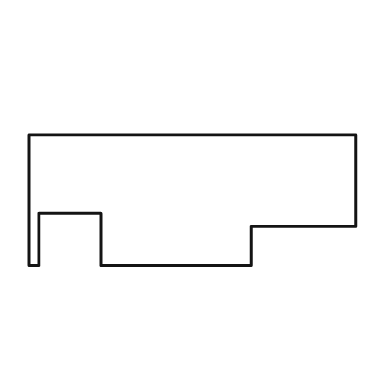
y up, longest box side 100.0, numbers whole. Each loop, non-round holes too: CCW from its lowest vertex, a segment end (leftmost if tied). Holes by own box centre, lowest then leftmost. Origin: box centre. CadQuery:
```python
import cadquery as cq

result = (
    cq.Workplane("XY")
    .moveTo(-50.0, -20.0)
    .lineTo(-47.0, -20.0)
    .lineTo(-47.0, -4.0)
    .lineTo(-28.0, -4.0)
    .lineTo(-28.0, -20.0)
    .lineTo(18.0, -20.0)
    .lineTo(18.0, -8.0)
    .lineTo(50.0, -8.0)
    .lineTo(50.0, 20.0)
    .lineTo(-50.0, 20.0)
    .close()
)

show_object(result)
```